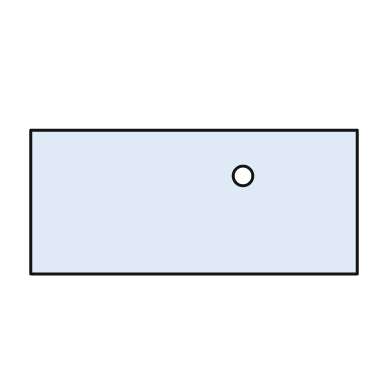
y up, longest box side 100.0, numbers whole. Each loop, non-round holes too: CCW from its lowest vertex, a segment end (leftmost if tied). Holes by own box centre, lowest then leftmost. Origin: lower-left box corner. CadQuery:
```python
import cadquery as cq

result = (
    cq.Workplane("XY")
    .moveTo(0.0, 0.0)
    .lineTo(100.0, 0.0)
    .lineTo(100.0, 44.0)
    .lineTo(0.0, 44.0)
    .close()
    .moveTo(65.0, 30.0)
    .circle(3.0)
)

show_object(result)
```